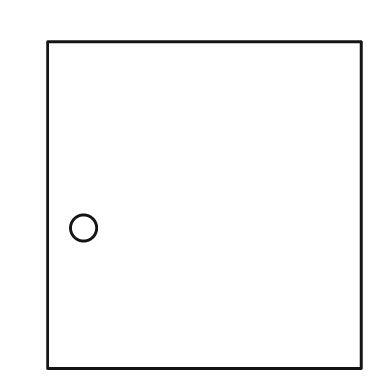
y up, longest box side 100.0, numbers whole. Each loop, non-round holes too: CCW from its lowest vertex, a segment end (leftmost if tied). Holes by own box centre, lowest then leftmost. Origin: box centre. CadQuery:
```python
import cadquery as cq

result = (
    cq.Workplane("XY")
    .moveTo(-48.0, -50.0)
    .lineTo(48.0, -50.0)
    .lineTo(48.0, 50.0)
    .lineTo(-48.0, 50.0)
    .close()
    .moveTo(-37.0, -7.0)
    .circle(4.0)
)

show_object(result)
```